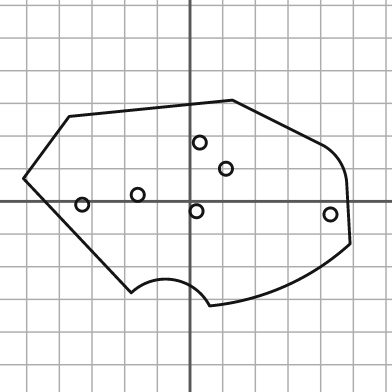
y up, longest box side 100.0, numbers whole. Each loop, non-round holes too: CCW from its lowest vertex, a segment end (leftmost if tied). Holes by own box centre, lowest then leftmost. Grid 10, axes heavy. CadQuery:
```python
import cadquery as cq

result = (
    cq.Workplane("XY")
    .moveTo(6.0, -32.0)
    .threePointArc((29.0, -26.0), (49.0, -13.0))
    .lineTo(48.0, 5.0)
    .threePointArc((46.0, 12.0), (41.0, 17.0))
    .lineTo(13.0, 31.0)
    .lineTo(-37.0, 26.0)
    .lineTo(-51.0, 7.0)
    .lineTo(-18.0, -28.0)
    .threePointArc((-5.0, -24.0), (6.0, -32.0))
    .close()
    .moveTo(43.0, -4.0)
    .circle(2.0)
    .moveTo(2.0, -3.0)
    .circle(2.0)
    .moveTo(-33.0, -1.0)
    .circle(2.0)
    .moveTo(-16.0, 2.0)
    .circle(2.0)
    .moveTo(11.0, 10.0)
    .circle(2.0)
    .moveTo(3.0, 18.0)
    .circle(2.0)
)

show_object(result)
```